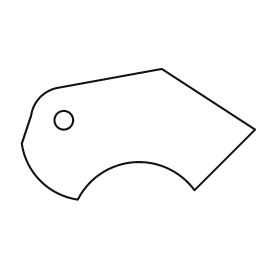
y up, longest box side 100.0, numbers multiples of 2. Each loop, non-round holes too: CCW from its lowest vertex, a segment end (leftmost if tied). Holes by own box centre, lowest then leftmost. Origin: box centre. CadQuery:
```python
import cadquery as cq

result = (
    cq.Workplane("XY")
    .moveTo(-26.0, -28.0)
    .threePointArc((-2.0, -12.0), (24.0, -24.0))
    .lineTo(50.0, 2.0)
    .lineTo(10.0, 28.0)
    .lineTo(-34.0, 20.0)
    .threePointArc((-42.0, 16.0), (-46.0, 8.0))
    .lineTo(-50.0, -4.0)
    .threePointArc((-42.0, -20.0), (-26.0, -28.0))
    .close()
    .moveTo(-32.0, 6.0)
    .circle(4.0)
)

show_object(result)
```